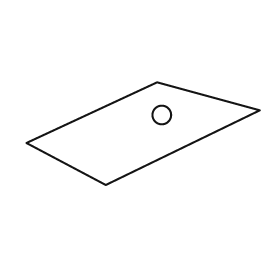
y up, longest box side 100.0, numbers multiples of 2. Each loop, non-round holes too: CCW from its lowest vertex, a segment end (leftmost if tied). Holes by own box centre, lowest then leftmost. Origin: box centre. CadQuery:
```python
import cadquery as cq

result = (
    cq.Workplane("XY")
    .moveTo(-16.0, -22.0)
    .lineTo(50.0, 10.0)
    .lineTo(6.0, 22.0)
    .lineTo(-50.0, -4.0)
    .close()
    .moveTo(8.0, 8.0)
    .circle(4.0)
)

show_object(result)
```